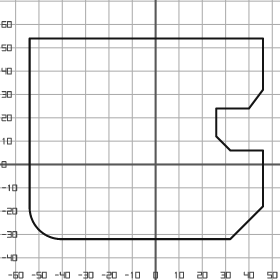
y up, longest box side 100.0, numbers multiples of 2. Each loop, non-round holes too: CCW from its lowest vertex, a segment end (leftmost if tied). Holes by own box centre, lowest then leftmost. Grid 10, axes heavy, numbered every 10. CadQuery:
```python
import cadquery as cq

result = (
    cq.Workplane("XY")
    .moveTo(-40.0, -32.0)
    .lineTo(32.0, -32.0)
    .lineTo(46.0, -18.0)
    .lineTo(46.0, 6.0)
    .lineTo(32.0, 6.0)
    .lineTo(26.0, 12.0)
    .lineTo(26.0, 24.0)
    .lineTo(40.0, 24.0)
    .lineTo(46.0, 32.0)
    .lineTo(46.0, 54.0)
    .lineTo(-54.0, 54.0)
    .lineTo(-54.0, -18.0)
    .threePointArc((-50.0, -28.0), (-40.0, -32.0))
    .close()
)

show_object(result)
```